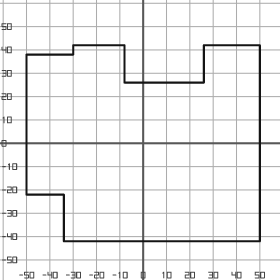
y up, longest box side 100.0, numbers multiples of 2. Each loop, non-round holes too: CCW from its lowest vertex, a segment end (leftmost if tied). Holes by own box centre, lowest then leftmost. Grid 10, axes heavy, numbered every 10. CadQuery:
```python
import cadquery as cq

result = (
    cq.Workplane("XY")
    .moveTo(-34.0, -42.0)
    .lineTo(50.0, -42.0)
    .lineTo(50.0, 42.0)
    .lineTo(26.0, 42.0)
    .lineTo(26.0, 26.0)
    .lineTo(-8.0, 26.0)
    .lineTo(-8.0, 42.0)
    .lineTo(-30.0, 42.0)
    .lineTo(-30.0, 38.0)
    .lineTo(-50.0, 38.0)
    .lineTo(-50.0, -22.0)
    .lineTo(-34.0, -22.0)
    .close()
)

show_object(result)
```